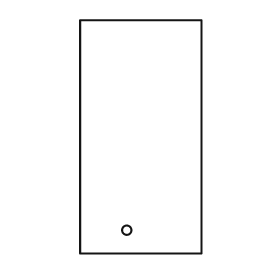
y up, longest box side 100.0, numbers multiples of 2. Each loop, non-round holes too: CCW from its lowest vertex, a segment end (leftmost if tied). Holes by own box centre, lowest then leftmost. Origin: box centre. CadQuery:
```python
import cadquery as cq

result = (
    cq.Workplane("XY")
    .moveTo(-26.0, -50.0)
    .lineTo(26.0, -50.0)
    .lineTo(26.0, 50.0)
    .lineTo(-26.0, 50.0)
    .close()
    .moveTo(-6.0, -40.0)
    .circle(2.0)
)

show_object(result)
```